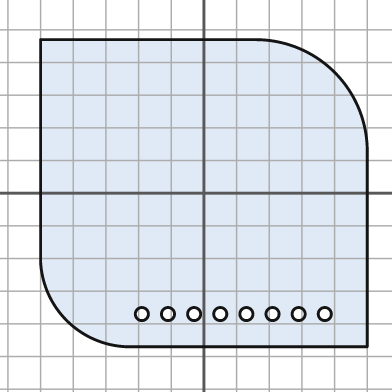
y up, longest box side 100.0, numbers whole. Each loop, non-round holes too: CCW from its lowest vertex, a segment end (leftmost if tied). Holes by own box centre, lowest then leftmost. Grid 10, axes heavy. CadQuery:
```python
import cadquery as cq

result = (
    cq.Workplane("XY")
    .moveTo(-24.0, -47.0)
    .lineTo(50.0, -47.0)
    .lineTo(50.0, 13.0)
    .threePointArc((40.0, 37.0), (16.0, 47.0))
    .lineTo(-50.0, 47.0)
    .lineTo(-50.0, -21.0)
    .threePointArc((-42.0, -39.0), (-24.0, -47.0))
    .close()
    .moveTo(-19.0, -37.0)
    .circle(2.0)
    .moveTo(-11.0, -37.0)
    .circle(2.0)
    .moveTo(-3.0, -37.0)
    .circle(2.0)
    .moveTo(5.0, -37.0)
    .circle(2.0)
    .moveTo(13.0, -37.0)
    .circle(2.0)
    .moveTo(21.0, -37.0)
    .circle(2.0)
    .moveTo(29.0, -37.0)
    .circle(2.0)
    .moveTo(37.0, -37.0)
    .circle(2.0)
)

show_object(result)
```